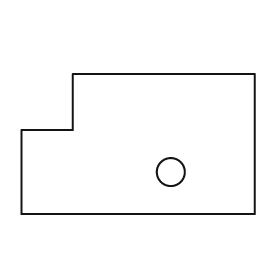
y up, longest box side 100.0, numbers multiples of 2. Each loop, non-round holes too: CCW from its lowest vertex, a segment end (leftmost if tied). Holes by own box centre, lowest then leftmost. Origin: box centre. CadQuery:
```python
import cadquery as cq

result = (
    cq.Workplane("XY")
    .moveTo(-50.0, -30.0)
    .lineTo(50.0, -30.0)
    .lineTo(50.0, 30.0)
    .lineTo(-28.0, 30.0)
    .lineTo(-28.0, 6.0)
    .lineTo(-50.0, 6.0)
    .close()
    .moveTo(14.0, -12.0)
    .circle(6.0)
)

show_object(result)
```